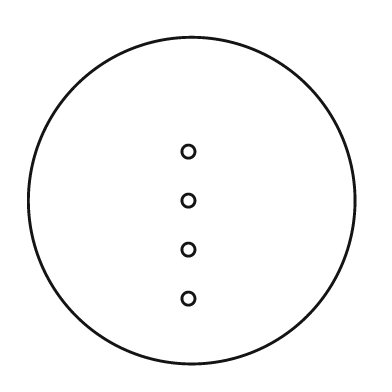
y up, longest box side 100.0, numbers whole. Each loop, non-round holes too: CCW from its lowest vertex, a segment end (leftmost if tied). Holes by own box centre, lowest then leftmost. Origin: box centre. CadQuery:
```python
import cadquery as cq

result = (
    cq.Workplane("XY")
    .moveTo(0.0, 0.0)
    .circle(50.0)
    .moveTo(-1.0, -30.0)
    .circle(2.0)
    .moveTo(-1.0, -15.0)
    .circle(2.0)
    .moveTo(-1.0, 0.0)
    .circle(2.0)
    .moveTo(-1.0, 15.0)
    .circle(2.0)
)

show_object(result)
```